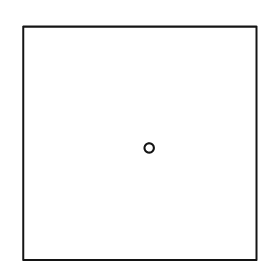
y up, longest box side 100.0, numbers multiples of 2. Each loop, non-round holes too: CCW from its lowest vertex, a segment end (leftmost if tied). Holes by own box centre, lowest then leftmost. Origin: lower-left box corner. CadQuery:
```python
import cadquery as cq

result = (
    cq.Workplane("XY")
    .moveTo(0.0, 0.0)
    .lineTo(100.0, 0.0)
    .lineTo(100.0, 100.0)
    .lineTo(0.0, 100.0)
    .close()
    .moveTo(54.0, 48.0)
    .circle(2.0)
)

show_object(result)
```